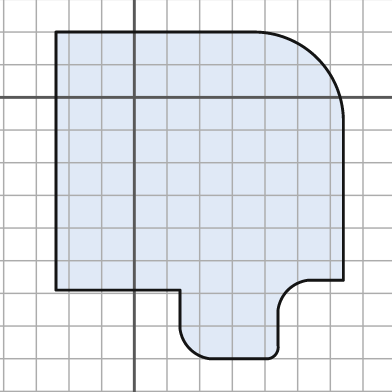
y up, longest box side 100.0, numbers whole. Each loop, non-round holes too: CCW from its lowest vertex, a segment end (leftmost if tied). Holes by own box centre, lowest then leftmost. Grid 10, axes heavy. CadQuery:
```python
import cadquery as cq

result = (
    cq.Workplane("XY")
    .moveTo(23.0, -80.0)
    .lineTo(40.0, -80.0)
    .threePointArc((43.0, -79.0), (44.0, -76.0))
    .lineTo(44.0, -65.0)
    .threePointArc((47.0, -59.0), (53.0, -56.0))
    .lineTo(64.0, -56.0)
    .lineTo(64.0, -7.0)
    .threePointArc((56.0, 12.0), (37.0, 20.0))
    .lineTo(-24.0, 20.0)
    .lineTo(-24.0, -59.0)
    .lineTo(14.0, -59.0)
    .lineTo(14.0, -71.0)
    .threePointArc((17.0, -77.0), (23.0, -80.0))
    .close()
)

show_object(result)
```